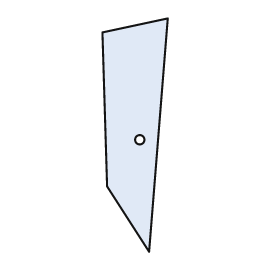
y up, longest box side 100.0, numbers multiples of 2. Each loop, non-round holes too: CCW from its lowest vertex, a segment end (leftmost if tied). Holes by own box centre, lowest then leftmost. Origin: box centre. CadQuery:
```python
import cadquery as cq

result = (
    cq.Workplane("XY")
    .moveTo(6.0, -50.0)
    .lineTo(14.0, 50.0)
    .lineTo(-14.0, 44.0)
    .lineTo(-12.0, -22.0)
    .close()
    .moveTo(2.0, -2.0)
    .circle(2.0)
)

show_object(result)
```